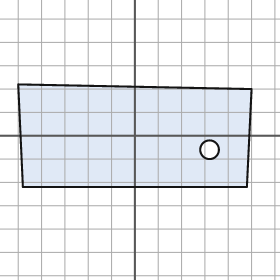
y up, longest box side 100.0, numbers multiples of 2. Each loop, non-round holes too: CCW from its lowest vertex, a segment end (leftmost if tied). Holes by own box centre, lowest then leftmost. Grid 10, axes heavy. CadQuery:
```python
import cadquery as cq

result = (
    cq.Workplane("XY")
    .moveTo(-48.0, -22.0)
    .lineTo(48.0, -22.0)
    .lineTo(50.0, 20.0)
    .lineTo(-50.0, 22.0)
    .close()
    .moveTo(32.0, -6.0)
    .circle(4.0)
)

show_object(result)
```